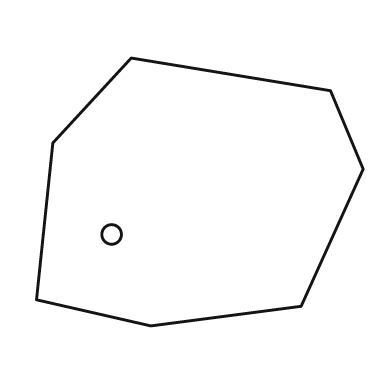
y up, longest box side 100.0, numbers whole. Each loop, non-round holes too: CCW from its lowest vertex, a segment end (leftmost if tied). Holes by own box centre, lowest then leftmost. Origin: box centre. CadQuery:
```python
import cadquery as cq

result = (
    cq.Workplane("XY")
    .moveTo(-15.0, -41.0)
    .lineTo(31.0, -35.0)
    .lineTo(50.0, 7.0)
    .lineTo(40.0, 31.0)
    .lineTo(-21.0, 41.0)
    .lineTo(-45.0, 15.0)
    .lineTo(-50.0, -33.0)
    .close()
    .moveTo(-27.0, -13.0)
    .circle(3.0)
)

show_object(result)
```